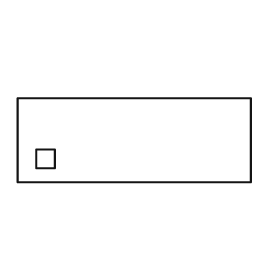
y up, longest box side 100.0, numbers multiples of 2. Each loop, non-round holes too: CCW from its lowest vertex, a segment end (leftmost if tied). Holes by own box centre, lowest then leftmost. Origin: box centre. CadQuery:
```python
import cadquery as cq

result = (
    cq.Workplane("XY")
    .moveTo(-50.0, -18.0)
    .lineTo(50.0, -18.0)
    .lineTo(50.0, 18.0)
    .lineTo(-50.0, 18.0)
    .close()
    .moveTo(-42.0, -12.0)
    .lineTo(-34.0, -12.0)
    .lineTo(-34.0, -4.0)
    .lineTo(-42.0, -4.0)
    .close()
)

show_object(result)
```